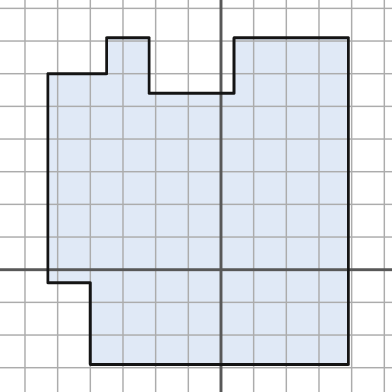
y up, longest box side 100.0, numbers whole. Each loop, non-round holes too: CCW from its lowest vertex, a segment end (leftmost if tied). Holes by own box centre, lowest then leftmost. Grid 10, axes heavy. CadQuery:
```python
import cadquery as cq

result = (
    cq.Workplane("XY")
    .moveTo(-40.0, -29.0)
    .lineTo(39.0, -29.0)
    .lineTo(39.0, 71.0)
    .lineTo(4.0, 71.0)
    .lineTo(4.0, 54.0)
    .lineTo(-22.0, 54.0)
    .lineTo(-22.0, 71.0)
    .lineTo(-35.0, 71.0)
    .lineTo(-35.0, 60.0)
    .lineTo(-53.0, 60.0)
    .lineTo(-53.0, -4.0)
    .lineTo(-40.0, -4.0)
    .close()
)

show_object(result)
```